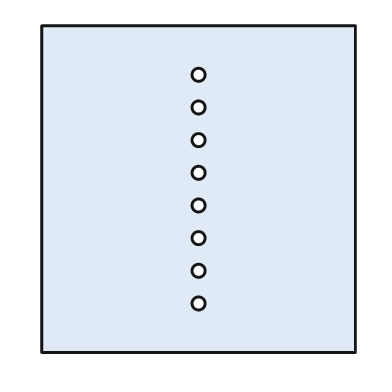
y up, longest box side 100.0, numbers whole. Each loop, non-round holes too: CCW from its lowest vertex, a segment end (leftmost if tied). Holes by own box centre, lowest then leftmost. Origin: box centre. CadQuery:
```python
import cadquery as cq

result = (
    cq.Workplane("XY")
    .moveTo(-48.0, -50.0)
    .lineTo(48.0, -50.0)
    .lineTo(48.0, 50.0)
    .lineTo(-48.0, 50.0)
    .close()
    .moveTo(0.0, -35.0)
    .circle(2.0)
    .moveTo(0.0, -25.0)
    .circle(2.0)
    .moveTo(0.0, -15.0)
    .circle(2.0)
    .moveTo(0.0, -5.0)
    .circle(2.0)
    .moveTo(0.0, 5.0)
    .circle(2.0)
    .moveTo(0.0, 15.0)
    .circle(2.0)
    .moveTo(0.0, 25.0)
    .circle(2.0)
    .moveTo(0.0, 35.0)
    .circle(2.0)
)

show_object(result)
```